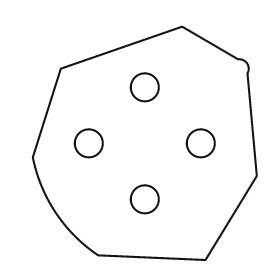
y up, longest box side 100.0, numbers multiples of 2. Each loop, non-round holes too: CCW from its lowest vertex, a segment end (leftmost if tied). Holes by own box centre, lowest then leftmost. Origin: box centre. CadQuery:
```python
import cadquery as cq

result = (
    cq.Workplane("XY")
    .moveTo(26.0, -50.0)
    .lineTo(48.0, -14.0)
    .lineTo(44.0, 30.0)
    .threePointArc((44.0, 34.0), (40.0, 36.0))
    .lineTo(16.0, 50.0)
    .lineTo(-36.0, 32.0)
    .lineTo(-48.0, -6.0)
    .threePointArc((-38.0, -30.0), (-20.0, -48.0))
    .close()
    .moveTo(0.0, -24.0)
    .circle(6.0)
    .moveTo(-24.0, 0.0)
    .circle(6.0)
    .moveTo(24.0, 0.0)
    .circle(6.0)
    .moveTo(0.0, 24.0)
    .circle(6.0)
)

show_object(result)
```